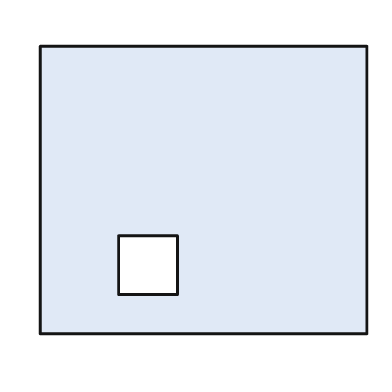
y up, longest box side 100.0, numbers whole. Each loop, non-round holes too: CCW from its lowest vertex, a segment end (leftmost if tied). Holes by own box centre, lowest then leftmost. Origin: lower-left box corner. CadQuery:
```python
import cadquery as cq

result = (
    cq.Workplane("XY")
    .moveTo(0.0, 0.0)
    .lineTo(100.0, 0.0)
    .lineTo(100.0, 88.0)
    .lineTo(0.0, 88.0)
    .close()
    .moveTo(24.0, 12.0)
    .lineTo(42.0, 12.0)
    .lineTo(42.0, 30.0)
    .lineTo(24.0, 30.0)
    .close()
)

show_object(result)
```